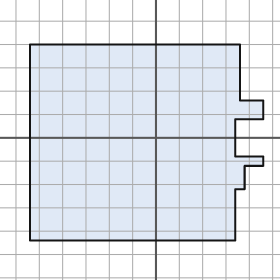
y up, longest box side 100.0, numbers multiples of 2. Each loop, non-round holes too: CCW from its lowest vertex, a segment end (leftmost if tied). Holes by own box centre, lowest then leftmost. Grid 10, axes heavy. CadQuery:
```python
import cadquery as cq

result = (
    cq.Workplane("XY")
    .moveTo(-54.0, -44.0)
    .lineTo(34.0, -44.0)
    .lineTo(34.0, -22.0)
    .lineTo(38.0, -22.0)
    .lineTo(38.0, -12.0)
    .lineTo(46.0, -12.0)
    .lineTo(46.0, -8.0)
    .lineTo(34.0, -8.0)
    .lineTo(34.0, 8.0)
    .lineTo(46.0, 8.0)
    .lineTo(46.0, 16.0)
    .lineTo(36.0, 16.0)
    .lineTo(36.0, 40.0)
    .lineTo(-54.0, 40.0)
    .close()
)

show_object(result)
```